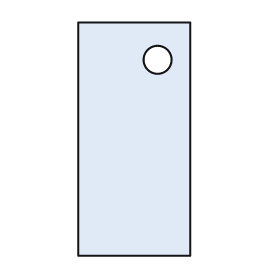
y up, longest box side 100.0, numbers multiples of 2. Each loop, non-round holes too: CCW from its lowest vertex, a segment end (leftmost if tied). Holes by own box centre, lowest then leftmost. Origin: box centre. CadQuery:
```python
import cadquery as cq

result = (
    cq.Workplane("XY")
    .moveTo(-24.0, -50.0)
    .lineTo(24.0, -50.0)
    .lineTo(24.0, 50.0)
    .lineTo(-24.0, 50.0)
    .close()
    .moveTo(10.0, 34.0)
    .circle(6.0)
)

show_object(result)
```